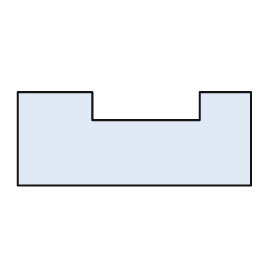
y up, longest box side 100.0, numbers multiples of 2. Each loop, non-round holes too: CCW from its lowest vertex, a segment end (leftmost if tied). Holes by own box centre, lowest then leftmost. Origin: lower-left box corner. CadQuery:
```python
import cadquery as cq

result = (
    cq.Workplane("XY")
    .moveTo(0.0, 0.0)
    .lineTo(100.0, 0.0)
    .lineTo(100.0, 40.0)
    .lineTo(78.0, 40.0)
    .lineTo(78.0, 28.0)
    .lineTo(32.0, 28.0)
    .lineTo(32.0, 40.0)
    .lineTo(0.0, 40.0)
    .close()
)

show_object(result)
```